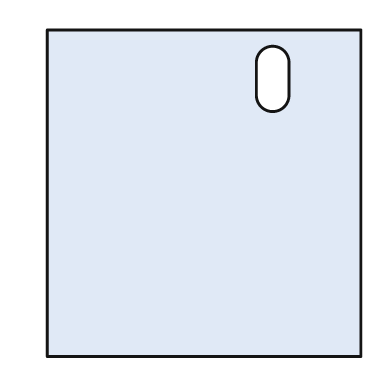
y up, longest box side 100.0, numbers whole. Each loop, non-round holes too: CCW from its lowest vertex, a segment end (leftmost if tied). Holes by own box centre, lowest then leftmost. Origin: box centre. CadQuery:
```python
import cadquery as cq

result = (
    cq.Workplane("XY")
    .moveTo(-48.0, -50.0)
    .lineTo(48.0, -50.0)
    .lineTo(48.0, 50.0)
    .lineTo(-48.0, 50.0)
    .close()
    .moveTo(16.0, 30.0)
    .threePointArc((21.0, 25.0), (26.0, 30.0))
    .lineTo(26.0, 40.0)
    .threePointArc((21.0, 45.0), (16.0, 40.0))
    .close()
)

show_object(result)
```